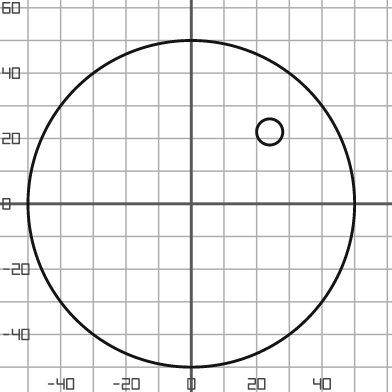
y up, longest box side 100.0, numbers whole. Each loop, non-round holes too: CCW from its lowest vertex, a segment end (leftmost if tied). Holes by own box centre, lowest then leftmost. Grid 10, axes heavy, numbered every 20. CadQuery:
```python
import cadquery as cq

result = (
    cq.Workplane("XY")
    .moveTo(0.0, 0.0)
    .circle(50.0)
    .moveTo(24.0, 22.0)
    .circle(4.0)
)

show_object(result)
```